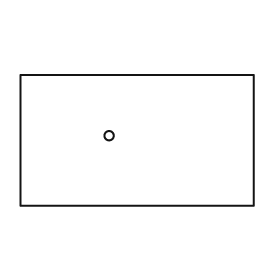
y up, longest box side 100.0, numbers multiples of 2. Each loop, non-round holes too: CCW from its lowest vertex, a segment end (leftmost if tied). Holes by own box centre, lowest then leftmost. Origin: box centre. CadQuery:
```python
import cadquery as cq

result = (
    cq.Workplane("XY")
    .moveTo(-50.0, -28.0)
    .lineTo(50.0, -28.0)
    .lineTo(50.0, 28.0)
    .lineTo(-50.0, 28.0)
    .close()
    .moveTo(-12.0, 2.0)
    .circle(2.0)
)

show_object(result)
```